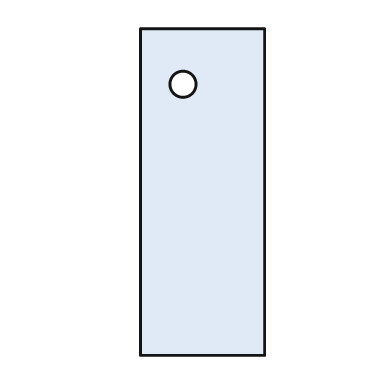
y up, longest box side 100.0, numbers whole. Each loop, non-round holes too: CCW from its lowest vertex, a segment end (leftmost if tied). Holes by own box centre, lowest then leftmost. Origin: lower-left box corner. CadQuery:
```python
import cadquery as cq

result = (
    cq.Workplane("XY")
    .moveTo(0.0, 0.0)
    .lineTo(38.0, 0.0)
    .lineTo(38.0, 100.0)
    .lineTo(0.0, 100.0)
    .close()
    .moveTo(13.0, 83.0)
    .circle(4.0)
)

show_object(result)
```